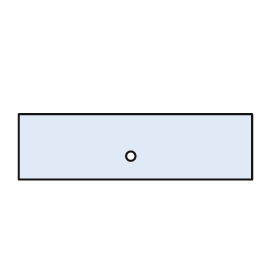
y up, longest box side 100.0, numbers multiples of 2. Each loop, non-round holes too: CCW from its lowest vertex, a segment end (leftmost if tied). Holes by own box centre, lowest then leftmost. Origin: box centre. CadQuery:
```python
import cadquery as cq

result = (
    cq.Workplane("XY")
    .moveTo(-50.0, -14.0)
    .lineTo(50.0, -14.0)
    .lineTo(50.0, 14.0)
    .lineTo(-50.0, 14.0)
    .close()
    .moveTo(-2.0, -4.0)
    .circle(2.0)
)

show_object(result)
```